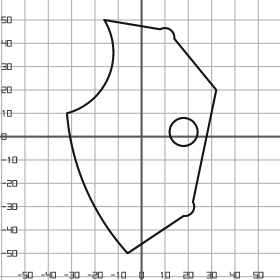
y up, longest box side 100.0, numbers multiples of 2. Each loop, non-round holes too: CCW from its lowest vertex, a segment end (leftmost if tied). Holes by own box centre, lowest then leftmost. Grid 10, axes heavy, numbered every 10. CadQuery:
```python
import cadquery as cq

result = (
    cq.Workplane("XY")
    .moveTo(-6.0, -50.0)
    .lineTo(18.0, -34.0)
    .threePointArc((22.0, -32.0), (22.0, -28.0))
    .lineTo(32.0, 20.0)
    .lineTo(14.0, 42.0)
    .threePointArc((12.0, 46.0), (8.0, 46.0))
    .lineTo(-16.0, 50.0)
    .threePointArc((-14.0, 26.0), (-32.0, 10.0))
    .threePointArc((-24.0, -22.0), (-6.0, -50.0))
    .close()
    .moveTo(18.0, 2.0)
    .circle(6.0)
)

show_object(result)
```